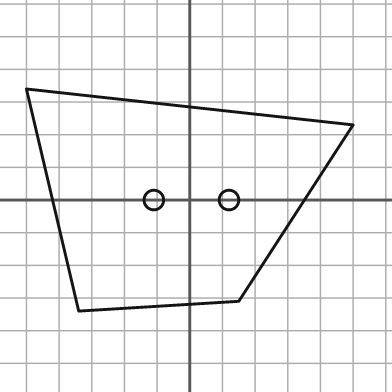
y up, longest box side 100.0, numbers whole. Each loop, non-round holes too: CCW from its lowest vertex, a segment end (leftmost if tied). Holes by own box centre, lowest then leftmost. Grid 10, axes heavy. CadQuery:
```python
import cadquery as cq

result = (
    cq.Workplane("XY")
    .moveTo(-34.0, -34.0)
    .lineTo(15.0, -31.0)
    .lineTo(50.0, 23.0)
    .lineTo(-50.0, 34.0)
    .close()
    .moveTo(-11.0, 0.0)
    .circle(3.0)
    .moveTo(12.0, 0.0)
    .circle(3.0)
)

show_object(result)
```